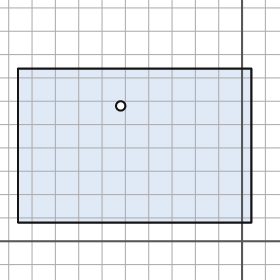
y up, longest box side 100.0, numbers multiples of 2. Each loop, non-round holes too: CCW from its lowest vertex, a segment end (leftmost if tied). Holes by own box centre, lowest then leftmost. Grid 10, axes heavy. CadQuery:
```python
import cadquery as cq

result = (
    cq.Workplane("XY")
    .moveTo(-96.0, 8.0)
    .lineTo(4.0, 8.0)
    .lineTo(4.0, 74.0)
    .lineTo(-96.0, 74.0)
    .close()
    .moveTo(-52.0, 58.0)
    .circle(2.0)
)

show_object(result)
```